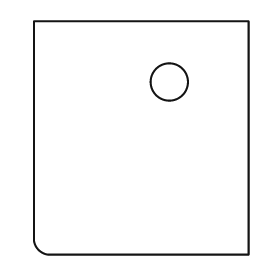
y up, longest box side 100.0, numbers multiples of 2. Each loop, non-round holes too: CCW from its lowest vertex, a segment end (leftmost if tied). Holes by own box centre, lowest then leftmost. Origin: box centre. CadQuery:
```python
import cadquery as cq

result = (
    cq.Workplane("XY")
    .moveTo(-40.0, -50.0)
    .lineTo(46.0, -50.0)
    .lineTo(46.0, 50.0)
    .lineTo(-46.0, 50.0)
    .lineTo(-46.0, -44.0)
    .threePointArc((-44.0, -48.0), (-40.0, -50.0))
    .close()
    .moveTo(12.0, 24.0)
    .circle(8.0)
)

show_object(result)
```